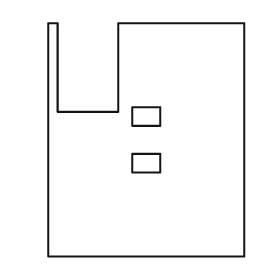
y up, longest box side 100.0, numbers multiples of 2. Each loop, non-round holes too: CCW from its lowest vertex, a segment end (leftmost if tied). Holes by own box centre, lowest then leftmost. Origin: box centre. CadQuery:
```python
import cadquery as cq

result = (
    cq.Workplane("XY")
    .moveTo(-42.0, -50.0)
    .lineTo(42.0, -50.0)
    .lineTo(42.0, 50.0)
    .lineTo(-12.0, 50.0)
    .lineTo(-12.0, 12.0)
    .lineTo(-38.0, 12.0)
    .lineTo(-38.0, 50.0)
    .lineTo(-42.0, 50.0)
    .close()
    .moveTo(-6.0, -14.0)
    .lineTo(6.0, -14.0)
    .lineTo(6.0, -6.0)
    .lineTo(-6.0, -6.0)
    .close()
    .moveTo(-6.0, 6.0)
    .lineTo(6.0, 6.0)
    .lineTo(6.0, 14.0)
    .lineTo(-6.0, 14.0)
    .close()
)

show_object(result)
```